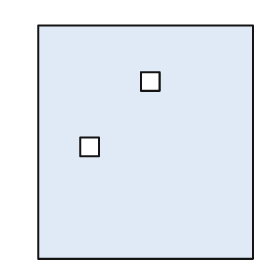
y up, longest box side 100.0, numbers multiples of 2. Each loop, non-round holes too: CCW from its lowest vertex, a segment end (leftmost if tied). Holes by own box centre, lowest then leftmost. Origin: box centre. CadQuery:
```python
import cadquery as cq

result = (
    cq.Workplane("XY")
    .moveTo(-46.0, -50.0)
    .lineTo(46.0, -50.0)
    .lineTo(46.0, 50.0)
    .lineTo(-46.0, 50.0)
    .close()
    .moveTo(-28.0, -6.0)
    .lineTo(-20.0, -6.0)
    .lineTo(-20.0, 2.0)
    .lineTo(-28.0, 2.0)
    .close()
    .moveTo(-2.0, 22.0)
    .lineTo(6.0, 22.0)
    .lineTo(6.0, 30.0)
    .lineTo(-2.0, 30.0)
    .close()
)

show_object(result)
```